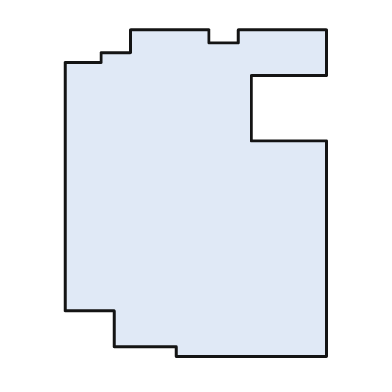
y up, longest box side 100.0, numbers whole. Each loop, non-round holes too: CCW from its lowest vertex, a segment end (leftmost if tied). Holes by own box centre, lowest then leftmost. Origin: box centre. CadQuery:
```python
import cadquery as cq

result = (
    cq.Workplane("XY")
    .moveTo(-6.0, -50.0)
    .lineTo(40.0, -50.0)
    .lineTo(40.0, 16.0)
    .lineTo(17.0, 16.0)
    .lineTo(17.0, 36.0)
    .lineTo(40.0, 36.0)
    .lineTo(40.0, 50.0)
    .lineTo(13.0, 50.0)
    .lineTo(13.0, 46.0)
    .lineTo(4.0, 46.0)
    .lineTo(4.0, 50.0)
    .lineTo(-20.0, 50.0)
    .lineTo(-20.0, 43.0)
    .lineTo(-29.0, 43.0)
    .lineTo(-29.0, 40.0)
    .lineTo(-40.0, 40.0)
    .lineTo(-40.0, -36.0)
    .lineTo(-25.0, -36.0)
    .lineTo(-25.0, -47.0)
    .lineTo(-6.0, -47.0)
    .close()
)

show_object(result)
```